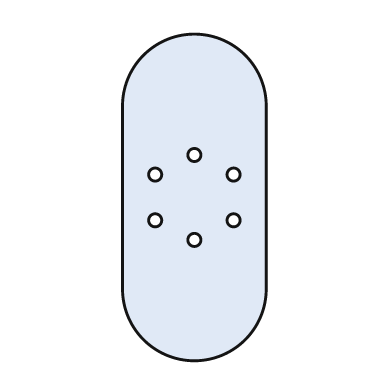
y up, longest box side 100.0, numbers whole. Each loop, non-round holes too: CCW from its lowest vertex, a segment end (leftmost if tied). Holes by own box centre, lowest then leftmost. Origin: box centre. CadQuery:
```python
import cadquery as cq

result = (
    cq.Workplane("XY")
    .moveTo(-22.0, -28.0)
    .threePointArc((0.0, -50.0), (22.0, -28.0))
    .lineTo(22.0, 28.0)
    .threePointArc((0.0, 50.0), (-22.0, 28.0))
    .close()
    .moveTo(0.0, -13.0)
    .circle(2.0)
    .moveTo(-12.0, -7.0)
    .circle(2.0)
    .moveTo(12.0, -7.0)
    .circle(2.0)
    .moveTo(-12.0, 7.0)
    .circle(2.0)
    .moveTo(12.0, 7.0)
    .circle(2.0)
    .moveTo(0.0, 13.0)
    .circle(2.0)
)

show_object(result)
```